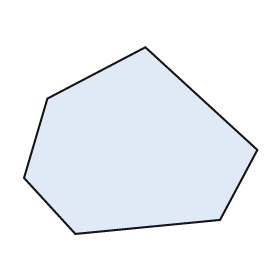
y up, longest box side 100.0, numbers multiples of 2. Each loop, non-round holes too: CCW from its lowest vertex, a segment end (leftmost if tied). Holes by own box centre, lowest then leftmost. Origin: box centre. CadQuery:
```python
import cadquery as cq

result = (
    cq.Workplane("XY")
    .moveTo(-28.0, -40.0)
    .lineTo(34.0, -34.0)
    .lineTo(50.0, -4.0)
    .lineTo(2.0, 40.0)
    .lineTo(-40.0, 18.0)
    .lineTo(-50.0, -16.0)
    .close()
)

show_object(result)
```